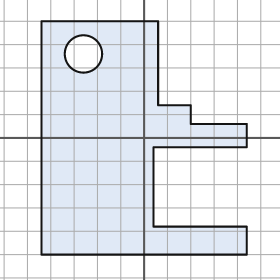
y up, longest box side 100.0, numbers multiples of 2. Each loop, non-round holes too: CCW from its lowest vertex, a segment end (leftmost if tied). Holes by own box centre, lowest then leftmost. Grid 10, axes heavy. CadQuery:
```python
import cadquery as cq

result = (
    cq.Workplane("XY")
    .moveTo(-44.0, -50.0)
    .lineTo(44.0, -50.0)
    .lineTo(44.0, -38.0)
    .lineTo(4.0, -38.0)
    .lineTo(4.0, -4.0)
    .lineTo(44.0, -4.0)
    .lineTo(44.0, 6.0)
    .lineTo(20.0, 6.0)
    .lineTo(20.0, 14.0)
    .lineTo(6.0, 14.0)
    .lineTo(6.0, 50.0)
    .lineTo(-44.0, 50.0)
    .close()
    .moveTo(-26.0, 36.0)
    .circle(8.0)
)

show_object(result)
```